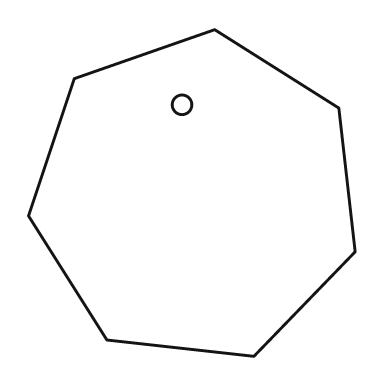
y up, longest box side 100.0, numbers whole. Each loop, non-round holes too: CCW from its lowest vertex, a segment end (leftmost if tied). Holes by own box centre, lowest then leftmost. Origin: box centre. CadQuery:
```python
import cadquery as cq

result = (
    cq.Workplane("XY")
    .moveTo(19.0, -50.0)
    .lineTo(50.0, -18.0)
    .lineTo(45.0, 26.0)
    .lineTo(7.0, 50.0)
    .lineTo(-36.0, 35.0)
    .lineTo(-50.0, -7.0)
    .lineTo(-26.0, -45.0)
    .close()
    .moveTo(-3.0, 27.0)
    .circle(3.0)
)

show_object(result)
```